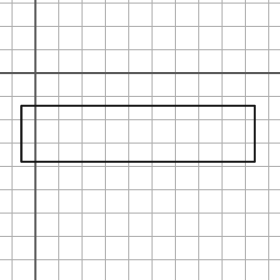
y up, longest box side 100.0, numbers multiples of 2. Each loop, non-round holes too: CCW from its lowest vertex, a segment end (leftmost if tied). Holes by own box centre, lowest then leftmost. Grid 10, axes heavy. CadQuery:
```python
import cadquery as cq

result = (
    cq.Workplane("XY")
    .moveTo(-6.0, -38.0)
    .lineTo(94.0, -38.0)
    .lineTo(94.0, -14.0)
    .lineTo(-6.0, -14.0)
    .close()
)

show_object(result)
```